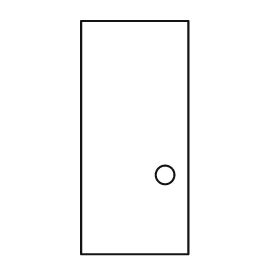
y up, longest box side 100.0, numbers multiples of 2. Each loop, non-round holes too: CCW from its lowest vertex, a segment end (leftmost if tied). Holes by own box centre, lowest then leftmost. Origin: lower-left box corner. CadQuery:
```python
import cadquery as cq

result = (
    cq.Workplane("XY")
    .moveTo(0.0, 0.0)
    .lineTo(46.0, 0.0)
    .lineTo(46.0, 100.0)
    .lineTo(0.0, 100.0)
    .close()
    .moveTo(36.0, 34.0)
    .circle(4.0)
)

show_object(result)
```